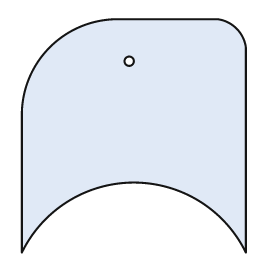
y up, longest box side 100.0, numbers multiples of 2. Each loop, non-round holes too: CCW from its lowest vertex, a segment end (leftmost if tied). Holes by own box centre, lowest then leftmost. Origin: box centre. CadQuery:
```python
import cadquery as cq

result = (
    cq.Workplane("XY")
    .moveTo(-48.0, -50.0)
    .threePointArc((0.0, -20.0), (48.0, -50.0))
    .lineTo(48.0, 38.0)
    .threePointArc((44.0, 46.0), (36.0, 50.0))
    .lineTo(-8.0, 50.0)
    .threePointArc((-36.0, 38.0), (-48.0, 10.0))
    .close()
    .moveTo(-2.0, 32.0)
    .circle(2.0)
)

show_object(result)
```